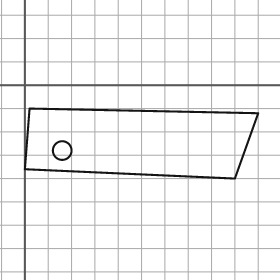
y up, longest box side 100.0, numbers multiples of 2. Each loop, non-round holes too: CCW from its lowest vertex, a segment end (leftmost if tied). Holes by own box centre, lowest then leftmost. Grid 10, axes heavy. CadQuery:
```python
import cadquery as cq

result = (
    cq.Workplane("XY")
    .moveTo(90.0, -40.0)
    .lineTo(100.0, -12.0)
    .lineTo(2.0, -10.0)
    .lineTo(0.0, -36.0)
    .close()
    .moveTo(16.0, -28.0)
    .circle(4.0)
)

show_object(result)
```